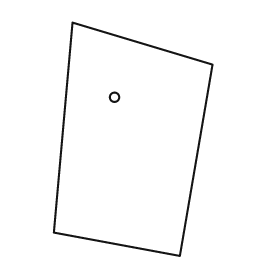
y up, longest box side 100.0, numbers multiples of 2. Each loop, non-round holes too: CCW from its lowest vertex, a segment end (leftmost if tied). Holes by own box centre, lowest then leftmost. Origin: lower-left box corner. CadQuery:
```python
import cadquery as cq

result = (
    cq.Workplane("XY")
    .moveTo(54.0, 0.0)
    .lineTo(68.0, 82.0)
    .lineTo(8.0, 100.0)
    .lineTo(0.0, 10.0)
    .close()
    .moveTo(26.0, 68.0)
    .circle(2.0)
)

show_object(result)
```